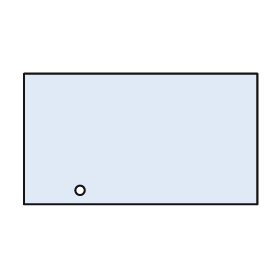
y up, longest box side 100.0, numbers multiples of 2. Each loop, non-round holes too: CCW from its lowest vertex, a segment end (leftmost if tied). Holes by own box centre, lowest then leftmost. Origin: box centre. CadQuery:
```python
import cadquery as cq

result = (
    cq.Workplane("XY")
    .moveTo(-50.0, -28.0)
    .lineTo(50.0, -28.0)
    .lineTo(50.0, 28.0)
    .lineTo(-50.0, 28.0)
    .close()
    .moveTo(-26.0, -22.0)
    .circle(2.0)
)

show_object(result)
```